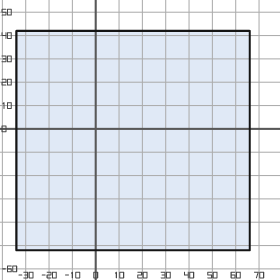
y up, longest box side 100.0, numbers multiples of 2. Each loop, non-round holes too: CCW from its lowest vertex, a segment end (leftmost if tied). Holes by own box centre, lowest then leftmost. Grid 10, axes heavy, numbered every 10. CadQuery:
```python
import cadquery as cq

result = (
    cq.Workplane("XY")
    .moveTo(-34.0, -52.0)
    .lineTo(66.0, -52.0)
    .lineTo(66.0, 42.0)
    .lineTo(-34.0, 42.0)
    .close()
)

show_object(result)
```